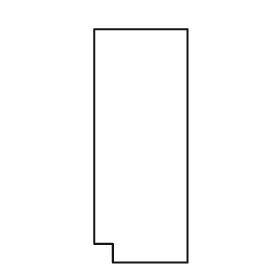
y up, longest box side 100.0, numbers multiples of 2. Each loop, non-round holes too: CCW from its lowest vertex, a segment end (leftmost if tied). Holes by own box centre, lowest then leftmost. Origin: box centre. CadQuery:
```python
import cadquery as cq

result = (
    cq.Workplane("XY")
    .moveTo(-12.0, -50.0)
    .lineTo(20.0, -50.0)
    .lineTo(20.0, 50.0)
    .lineTo(-20.0, 50.0)
    .lineTo(-20.0, -42.0)
    .lineTo(-12.0, -42.0)
    .close()
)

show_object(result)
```